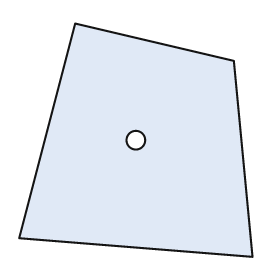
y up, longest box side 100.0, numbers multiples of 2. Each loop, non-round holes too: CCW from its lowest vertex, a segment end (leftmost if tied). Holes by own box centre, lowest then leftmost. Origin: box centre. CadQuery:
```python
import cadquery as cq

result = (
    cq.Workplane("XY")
    .moveTo(50.0, -50.0)
    .lineTo(42.0, 34.0)
    .lineTo(-26.0, 50.0)
    .lineTo(-50.0, -42.0)
    .close()
    .moveTo(0.0, 0.0)
    .circle(4.0)
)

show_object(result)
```